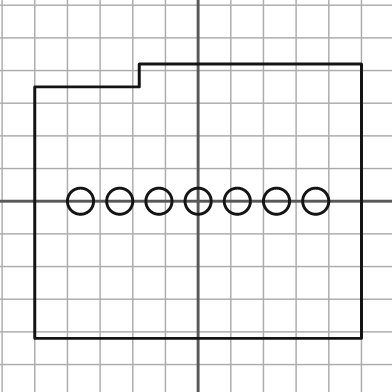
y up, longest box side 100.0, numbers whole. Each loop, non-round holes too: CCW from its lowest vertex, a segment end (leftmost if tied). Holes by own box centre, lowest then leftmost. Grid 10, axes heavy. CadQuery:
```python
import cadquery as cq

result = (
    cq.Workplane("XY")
    .moveTo(-50.0, -42.0)
    .lineTo(50.0, -42.0)
    .lineTo(50.0, 42.0)
    .lineTo(-18.0, 42.0)
    .lineTo(-18.0, 35.0)
    .lineTo(-50.0, 35.0)
    .close()
    .moveTo(-36.0, 0.0)
    .circle(4.0)
    .moveTo(-24.0, 0.0)
    .circle(4.0)
    .moveTo(-12.0, 0.0)
    .circle(4.0)
    .moveTo(0.0, 0.0)
    .circle(4.0)
    .moveTo(12.0, 0.0)
    .circle(4.0)
    .moveTo(24.0, 0.0)
    .circle(4.0)
    .moveTo(36.0, 0.0)
    .circle(4.0)
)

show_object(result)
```